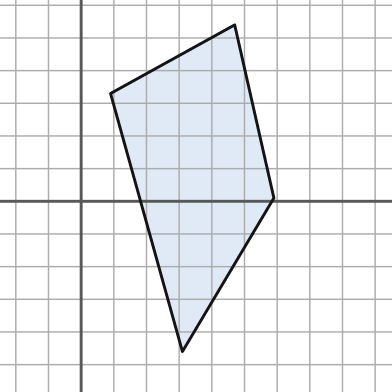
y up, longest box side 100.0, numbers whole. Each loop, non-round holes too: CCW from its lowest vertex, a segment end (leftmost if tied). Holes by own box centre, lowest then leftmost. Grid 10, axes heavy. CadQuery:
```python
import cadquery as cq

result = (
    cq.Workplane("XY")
    .moveTo(31.0, -46.0)
    .lineTo(59.0, 1.0)
    .lineTo(47.0, 54.0)
    .lineTo(9.0, 33.0)
    .close()
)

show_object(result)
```